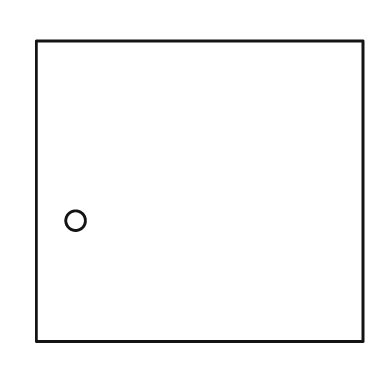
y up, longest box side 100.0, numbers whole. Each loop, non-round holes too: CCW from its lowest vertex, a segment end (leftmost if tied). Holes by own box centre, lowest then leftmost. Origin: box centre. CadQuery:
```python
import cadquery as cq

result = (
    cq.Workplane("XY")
    .moveTo(-50.0, -46.0)
    .lineTo(50.0, -46.0)
    .lineTo(50.0, 46.0)
    .lineTo(-50.0, 46.0)
    .close()
    .moveTo(-38.0, -9.0)
    .circle(3.0)
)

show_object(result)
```